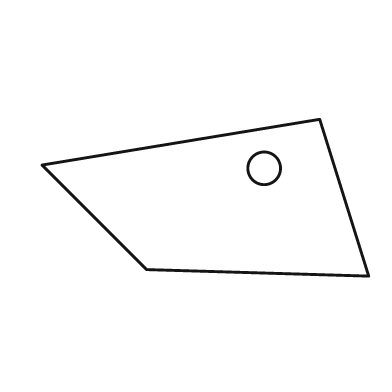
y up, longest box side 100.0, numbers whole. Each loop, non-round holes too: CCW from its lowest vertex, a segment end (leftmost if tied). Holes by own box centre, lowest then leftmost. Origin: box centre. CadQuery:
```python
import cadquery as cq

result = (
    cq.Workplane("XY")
    .moveTo(50.0, -24.0)
    .lineTo(35.0, 24.0)
    .lineTo(-50.0, 10.0)
    .lineTo(-18.0, -22.0)
    .close()
    .moveTo(18.0, 9.0)
    .circle(5.0)
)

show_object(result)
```